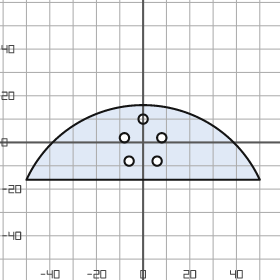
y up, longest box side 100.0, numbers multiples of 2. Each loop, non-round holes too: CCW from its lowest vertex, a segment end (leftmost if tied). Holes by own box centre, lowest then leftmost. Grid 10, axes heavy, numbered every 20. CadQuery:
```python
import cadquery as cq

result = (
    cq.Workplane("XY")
    .moveTo(-50.0, -16.0)
    .lineTo(50.0, -16.0)
    .threePointArc((0.0, 16.0), (-50.0, -16.0))
    .close()
    .moveTo(-6.0, -8.0)
    .circle(2.0)
    .moveTo(6.0, -8.0)
    .circle(2.0)
    .moveTo(-8.0, 2.0)
    .circle(2.0)
    .moveTo(8.0, 2.0)
    .circle(2.0)
    .moveTo(0.0, 10.0)
    .circle(2.0)
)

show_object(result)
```